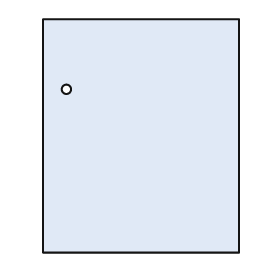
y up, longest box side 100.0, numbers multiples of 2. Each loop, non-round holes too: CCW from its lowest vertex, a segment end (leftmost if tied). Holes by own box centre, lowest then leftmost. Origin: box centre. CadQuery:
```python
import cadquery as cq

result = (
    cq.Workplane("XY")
    .moveTo(-42.0, -50.0)
    .lineTo(42.0, -50.0)
    .lineTo(42.0, 50.0)
    .lineTo(-42.0, 50.0)
    .close()
    .moveTo(-32.0, 20.0)
    .circle(2.0)
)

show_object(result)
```